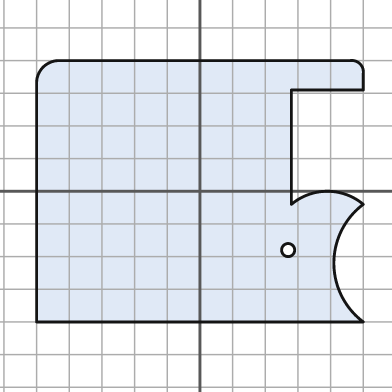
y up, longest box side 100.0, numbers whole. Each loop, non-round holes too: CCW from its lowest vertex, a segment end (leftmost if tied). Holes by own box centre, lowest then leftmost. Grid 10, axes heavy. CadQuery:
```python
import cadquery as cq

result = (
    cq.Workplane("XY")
    .moveTo(-50.0, -40.0)
    .lineTo(50.0, -40.0)
    .threePointArc((41.0, -22.0), (50.0, -4.0))
    .threePointArc((39.0, 0.0), (28.0, -4.0))
    .lineTo(28.0, 31.0)
    .lineTo(50.0, 31.0)
    .lineTo(50.0, 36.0)
    .threePointArc((49.0, 39.0), (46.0, 40.0))
    .lineTo(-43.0, 40.0)
    .threePointArc((-48.0, 38.0), (-50.0, 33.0))
    .close()
    .moveTo(27.0, -18.0)
    .circle(2.0)
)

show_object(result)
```